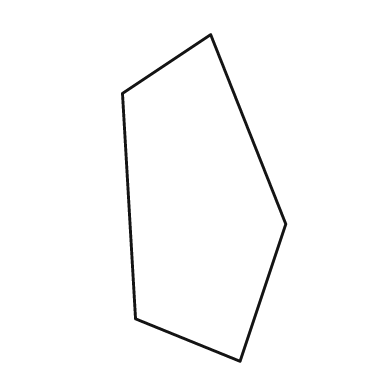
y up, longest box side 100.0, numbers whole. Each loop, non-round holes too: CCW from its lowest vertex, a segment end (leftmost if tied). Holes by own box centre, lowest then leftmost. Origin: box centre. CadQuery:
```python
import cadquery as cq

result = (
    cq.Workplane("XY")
    .moveTo(11.0, -50.0)
    .lineTo(25.0, -8.0)
    .lineTo(2.0, 50.0)
    .lineTo(-25.0, 32.0)
    .lineTo(-21.0, -37.0)
    .close()
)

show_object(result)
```